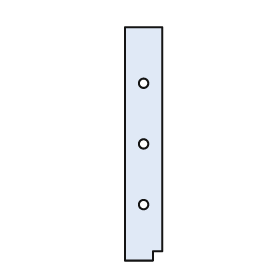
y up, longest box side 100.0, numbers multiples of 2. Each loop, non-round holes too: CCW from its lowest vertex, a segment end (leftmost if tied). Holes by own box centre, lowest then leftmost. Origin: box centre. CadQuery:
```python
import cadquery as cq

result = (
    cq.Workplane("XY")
    .moveTo(-8.0, -50.0)
    .lineTo(4.0, -50.0)
    .lineTo(4.0, -46.0)
    .lineTo(8.0, -46.0)
    .lineTo(8.0, 50.0)
    .lineTo(-8.0, 50.0)
    .close()
    .moveTo(0.0, -26.0)
    .circle(2.0)
    .moveTo(0.0, 0.0)
    .circle(2.0)
    .moveTo(0.0, 26.0)
    .circle(2.0)
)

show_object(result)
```